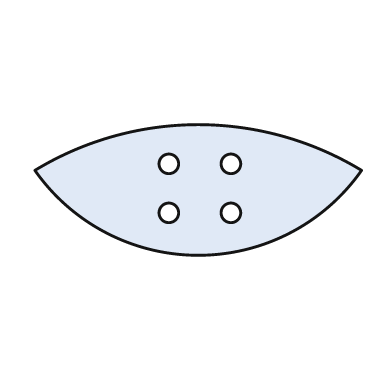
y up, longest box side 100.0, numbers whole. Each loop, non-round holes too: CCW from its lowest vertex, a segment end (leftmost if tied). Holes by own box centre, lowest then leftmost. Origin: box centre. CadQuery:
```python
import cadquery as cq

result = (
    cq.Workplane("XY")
    .moveTo(-50.0, 6.0)
    .threePointArc((0.0, -20.0), (50.0, 6.0))
    .threePointArc((0.0, 20.0), (-50.0, 6.0))
    .close()
    .moveTo(-9.0, -7.0)
    .circle(3.0)
    .moveTo(10.0, -7.0)
    .circle(3.0)
    .moveTo(-9.0, 8.0)
    .circle(3.0)
    .moveTo(10.0, 8.0)
    .circle(3.0)
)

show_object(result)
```